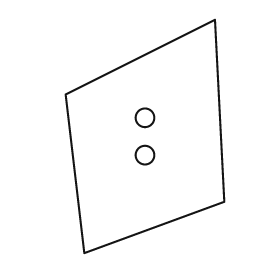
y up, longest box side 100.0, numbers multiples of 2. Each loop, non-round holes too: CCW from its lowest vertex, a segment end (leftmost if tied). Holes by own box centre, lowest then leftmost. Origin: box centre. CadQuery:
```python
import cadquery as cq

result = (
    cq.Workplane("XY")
    .moveTo(-26.0, -50.0)
    .lineTo(34.0, -28.0)
    .lineTo(30.0, 50.0)
    .lineTo(-34.0, 18.0)
    .close()
    .moveTo(0.0, -8.0)
    .circle(4.0)
    .moveTo(0.0, 8.0)
    .circle(4.0)
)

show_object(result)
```